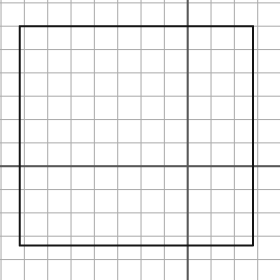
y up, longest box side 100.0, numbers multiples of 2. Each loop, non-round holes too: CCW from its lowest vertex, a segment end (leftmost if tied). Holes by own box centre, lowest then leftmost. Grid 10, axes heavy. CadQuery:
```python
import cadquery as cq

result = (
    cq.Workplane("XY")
    .moveTo(-72.0, -34.0)
    .lineTo(28.0, -34.0)
    .lineTo(28.0, 60.0)
    .lineTo(-72.0, 60.0)
    .close()
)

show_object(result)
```